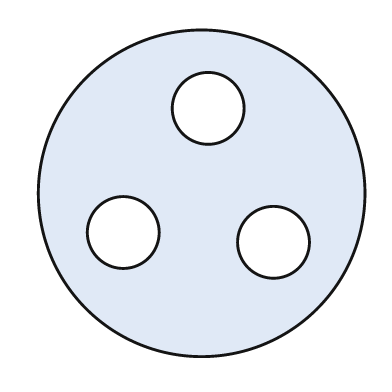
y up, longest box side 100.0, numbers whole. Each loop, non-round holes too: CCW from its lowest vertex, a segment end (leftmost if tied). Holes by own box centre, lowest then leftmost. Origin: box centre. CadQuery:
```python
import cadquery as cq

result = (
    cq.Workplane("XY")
    .moveTo(0.0, 0.0)
    .circle(50.0)
    .moveTo(22.0, -15.0)
    .circle(11.0)
    .moveTo(-24.0, -12.0)
    .circle(11.0)
    .moveTo(2.0, 26.0)
    .circle(11.0)
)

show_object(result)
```